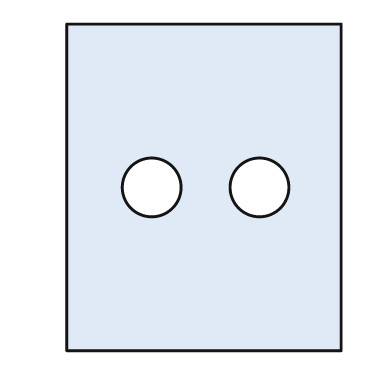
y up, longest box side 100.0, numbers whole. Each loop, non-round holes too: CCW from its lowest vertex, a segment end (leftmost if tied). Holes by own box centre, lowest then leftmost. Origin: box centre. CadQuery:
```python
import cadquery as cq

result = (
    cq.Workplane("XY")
    .moveTo(-42.0, -50.0)
    .lineTo(42.0, -50.0)
    .lineTo(42.0, 50.0)
    .lineTo(-42.0, 50.0)
    .close()
    .moveTo(-16.0, 0.0)
    .circle(9.0)
    .moveTo(17.0, 0.0)
    .circle(9.0)
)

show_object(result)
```